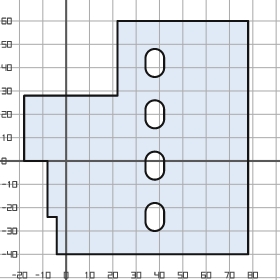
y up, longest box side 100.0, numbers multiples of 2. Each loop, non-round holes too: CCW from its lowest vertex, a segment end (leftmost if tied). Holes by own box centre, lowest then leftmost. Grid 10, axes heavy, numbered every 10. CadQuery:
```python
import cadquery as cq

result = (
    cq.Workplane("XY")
    .moveTo(-4.0, -40.0)
    .lineTo(78.0, -40.0)
    .lineTo(78.0, 60.0)
    .lineTo(22.0, 60.0)
    .lineTo(22.0, 28.0)
    .lineTo(-18.0, 28.0)
    .lineTo(-18.0, 0.0)
    .lineTo(-8.0, 0.0)
    .lineTo(-8.0, -24.0)
    .lineTo(-4.0, -24.0)
    .close()
    .moveTo(34.0, -26.0)
    .threePointArc((38.0, -30.0), (42.0, -26.0))
    .lineTo(42.0, -22.0)
    .threePointArc((38.0, -18.0), (34.0, -22.0))
    .close()
    .moveTo(34.0, -4.0)
    .threePointArc((38.0, -8.0), (42.0, -4.0))
    .lineTo(42.0, 0.0)
    .threePointArc((38.0, 4.0), (34.0, 0.0))
    .close()
    .moveTo(34.0, 18.0)
    .threePointArc((38.0, 14.0), (42.0, 18.0))
    .lineTo(42.0, 22.0)
    .threePointArc((38.0, 26.0), (34.0, 22.0))
    .close()
    .moveTo(34.0, 40.0)
    .threePointArc((38.0, 36.0), (42.0, 40.0))
    .lineTo(42.0, 44.0)
    .threePointArc((38.0, 48.0), (34.0, 44.0))
    .close()
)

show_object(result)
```